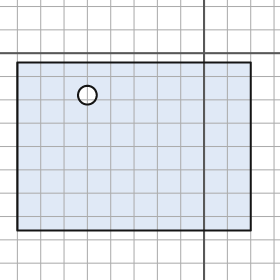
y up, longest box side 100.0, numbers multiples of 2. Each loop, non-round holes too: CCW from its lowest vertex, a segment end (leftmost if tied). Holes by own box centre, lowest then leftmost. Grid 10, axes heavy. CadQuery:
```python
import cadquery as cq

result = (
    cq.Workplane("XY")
    .moveTo(-80.0, -76.0)
    .lineTo(20.0, -76.0)
    .lineTo(20.0, -4.0)
    .lineTo(-80.0, -4.0)
    .close()
    .moveTo(-50.0, -18.0)
    .circle(4.0)
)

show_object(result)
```